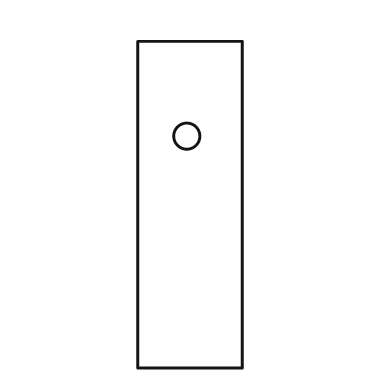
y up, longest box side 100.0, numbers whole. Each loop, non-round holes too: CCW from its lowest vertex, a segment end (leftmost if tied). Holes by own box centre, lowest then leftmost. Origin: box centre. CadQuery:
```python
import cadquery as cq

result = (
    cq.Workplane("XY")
    .moveTo(-16.0, -50.0)
    .lineTo(16.0, -50.0)
    .lineTo(16.0, 50.0)
    .lineTo(-16.0, 50.0)
    .close()
    .moveTo(-1.0, 21.0)
    .circle(4.0)
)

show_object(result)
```